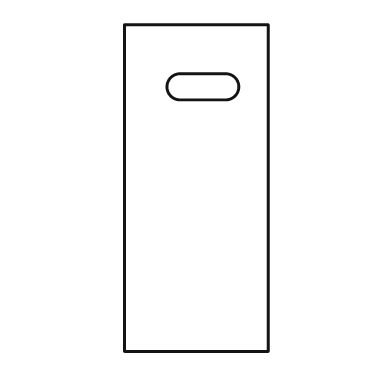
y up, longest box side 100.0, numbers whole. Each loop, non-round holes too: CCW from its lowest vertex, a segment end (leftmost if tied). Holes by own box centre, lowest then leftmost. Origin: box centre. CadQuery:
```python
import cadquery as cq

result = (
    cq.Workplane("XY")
    .moveTo(-22.0, -50.0)
    .lineTo(22.0, -50.0)
    .lineTo(22.0, 50.0)
    .lineTo(-22.0, 50.0)
    .close()
    .moveTo(-5.0, 27.0)
    .lineTo(9.0, 27.0)
    .threePointArc((13.0, 31.0), (9.0, 35.0))
    .lineTo(-5.0, 35.0)
    .threePointArc((-9.0, 31.0), (-5.0, 27.0))
    .close()
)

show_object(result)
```